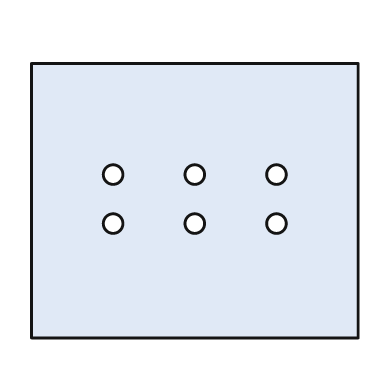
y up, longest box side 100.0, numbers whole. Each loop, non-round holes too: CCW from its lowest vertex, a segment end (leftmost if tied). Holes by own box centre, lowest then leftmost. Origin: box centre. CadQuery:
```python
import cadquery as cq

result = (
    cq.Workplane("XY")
    .moveTo(-50.0, -42.0)
    .lineTo(50.0, -42.0)
    .lineTo(50.0, 42.0)
    .lineTo(-50.0, 42.0)
    .close()
    .moveTo(-25.0, -7.0)
    .circle(3.0)
    .moveTo(0.0, -7.0)
    .circle(3.0)
    .moveTo(25.0, -7.0)
    .circle(3.0)
    .moveTo(-25.0, 8.0)
    .circle(3.0)
    .moveTo(0.0, 8.0)
    .circle(3.0)
    .moveTo(25.0, 8.0)
    .circle(3.0)
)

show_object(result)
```